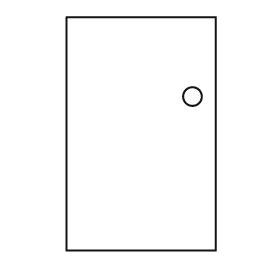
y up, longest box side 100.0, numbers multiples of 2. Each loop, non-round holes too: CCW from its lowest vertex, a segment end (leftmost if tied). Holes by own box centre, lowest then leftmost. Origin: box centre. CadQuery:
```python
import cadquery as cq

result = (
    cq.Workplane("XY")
    .moveTo(-32.0, -50.0)
    .lineTo(32.0, -50.0)
    .lineTo(32.0, 50.0)
    .lineTo(-32.0, 50.0)
    .close()
    .moveTo(22.0, 16.0)
    .circle(4.0)
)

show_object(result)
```